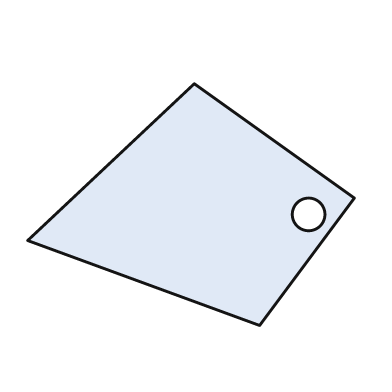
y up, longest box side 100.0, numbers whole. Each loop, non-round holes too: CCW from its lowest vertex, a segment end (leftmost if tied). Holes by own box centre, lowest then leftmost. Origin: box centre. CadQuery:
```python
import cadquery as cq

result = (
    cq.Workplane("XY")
    .moveTo(21.0, -37.0)
    .lineTo(50.0, 2.0)
    .lineTo(1.0, 37.0)
    .lineTo(-50.0, -11.0)
    .close()
    .moveTo(36.0, -3.0)
    .circle(5.0)
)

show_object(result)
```